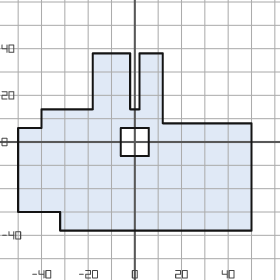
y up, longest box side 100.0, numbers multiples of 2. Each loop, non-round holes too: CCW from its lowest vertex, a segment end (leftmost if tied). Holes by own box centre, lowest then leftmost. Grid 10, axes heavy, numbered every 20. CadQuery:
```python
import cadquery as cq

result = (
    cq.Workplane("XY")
    .moveTo(-32.0, -38.0)
    .lineTo(50.0, -38.0)
    .lineTo(50.0, 8.0)
    .lineTo(12.0, 8.0)
    .lineTo(12.0, 38.0)
    .lineTo(2.0, 38.0)
    .lineTo(2.0, 14.0)
    .lineTo(-2.0, 14.0)
    .lineTo(-2.0, 38.0)
    .lineTo(-18.0, 38.0)
    .lineTo(-18.0, 14.0)
    .lineTo(-40.0, 14.0)
    .lineTo(-40.0, 6.0)
    .lineTo(-50.0, 6.0)
    .lineTo(-50.0, -30.0)
    .lineTo(-32.0, -30.0)
    .close()
    .moveTo(-6.0, -6.0)
    .lineTo(6.0, -6.0)
    .lineTo(6.0, 6.0)
    .lineTo(-6.0, 6.0)
    .close()
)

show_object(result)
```